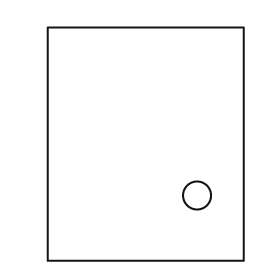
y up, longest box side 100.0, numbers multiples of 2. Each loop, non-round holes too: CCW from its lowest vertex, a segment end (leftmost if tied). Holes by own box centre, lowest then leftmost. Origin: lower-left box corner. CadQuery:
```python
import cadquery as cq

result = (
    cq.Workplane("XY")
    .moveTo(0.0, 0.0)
    .lineTo(84.0, 0.0)
    .lineTo(84.0, 100.0)
    .lineTo(0.0, 100.0)
    .close()
    .moveTo(64.0, 28.0)
    .circle(6.0)
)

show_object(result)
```